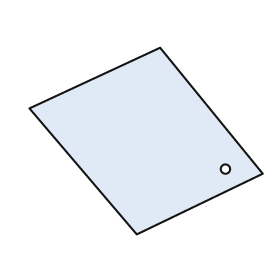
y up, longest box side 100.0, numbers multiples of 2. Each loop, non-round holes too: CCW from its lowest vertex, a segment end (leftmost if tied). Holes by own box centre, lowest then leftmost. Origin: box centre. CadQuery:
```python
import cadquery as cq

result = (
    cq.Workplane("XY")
    .moveTo(-4.0, -40.0)
    .lineTo(50.0, -14.0)
    .lineTo(6.0, 40.0)
    .lineTo(-50.0, 14.0)
    .close()
    .moveTo(34.0, -12.0)
    .circle(2.0)
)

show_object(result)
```